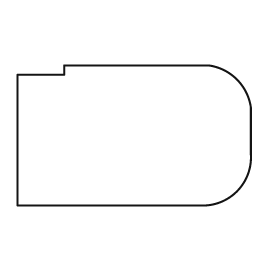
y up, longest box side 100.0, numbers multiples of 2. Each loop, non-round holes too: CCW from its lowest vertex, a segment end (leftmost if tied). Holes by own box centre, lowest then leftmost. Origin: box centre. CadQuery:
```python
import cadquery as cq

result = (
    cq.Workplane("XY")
    .moveTo(-50.0, -30.0)
    .lineTo(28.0, -30.0)
    .threePointArc((44.0, -24.0), (50.0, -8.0))
    .lineTo(50.0, 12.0)
    .threePointArc((44.0, 24.0), (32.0, 30.0))
    .lineTo(-30.0, 30.0)
    .lineTo(-30.0, 26.0)
    .lineTo(-50.0, 26.0)
    .close()
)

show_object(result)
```